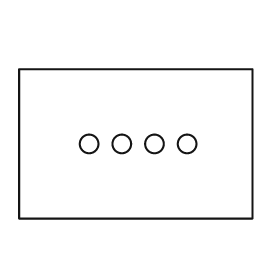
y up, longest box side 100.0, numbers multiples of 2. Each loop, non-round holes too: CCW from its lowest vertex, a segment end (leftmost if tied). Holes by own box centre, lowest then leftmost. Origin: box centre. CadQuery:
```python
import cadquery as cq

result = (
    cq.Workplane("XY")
    .moveTo(-50.0, -32.0)
    .lineTo(50.0, -32.0)
    .lineTo(50.0, 32.0)
    .lineTo(-50.0, 32.0)
    .close()
    .moveTo(-20.0, 0.0)
    .circle(4.0)
    .moveTo(-6.0, 0.0)
    .circle(4.0)
    .moveTo(8.0, 0.0)
    .circle(4.0)
    .moveTo(22.0, 0.0)
    .circle(4.0)
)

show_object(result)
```